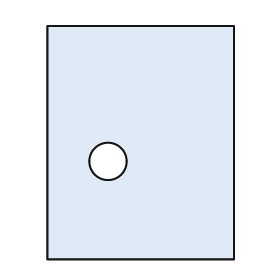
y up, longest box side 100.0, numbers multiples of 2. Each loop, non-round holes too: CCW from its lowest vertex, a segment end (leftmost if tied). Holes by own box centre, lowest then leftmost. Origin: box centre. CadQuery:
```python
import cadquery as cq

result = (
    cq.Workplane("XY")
    .moveTo(-40.0, -50.0)
    .lineTo(40.0, -50.0)
    .lineTo(40.0, 50.0)
    .lineTo(-40.0, 50.0)
    .close()
    .moveTo(-14.0, -8.0)
    .circle(8.0)
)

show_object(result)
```